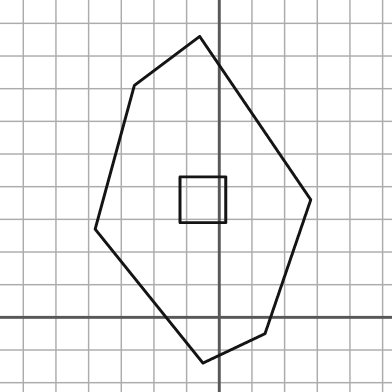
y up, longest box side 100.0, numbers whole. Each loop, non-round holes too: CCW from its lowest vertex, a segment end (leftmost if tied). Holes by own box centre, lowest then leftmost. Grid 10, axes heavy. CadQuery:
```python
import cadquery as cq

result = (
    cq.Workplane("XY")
    .moveTo(-5.0, -14.0)
    .lineTo(14.0, -5.0)
    .lineTo(28.0, 36.0)
    .lineTo(-6.0, 86.0)
    .lineTo(-26.0, 71.0)
    .lineTo(-38.0, 27.0)
    .close()
    .moveTo(-12.0, 29.0)
    .lineTo(2.0, 29.0)
    .lineTo(2.0, 43.0)
    .lineTo(-12.0, 43.0)
    .close()
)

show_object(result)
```